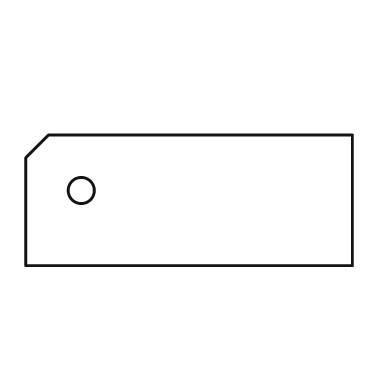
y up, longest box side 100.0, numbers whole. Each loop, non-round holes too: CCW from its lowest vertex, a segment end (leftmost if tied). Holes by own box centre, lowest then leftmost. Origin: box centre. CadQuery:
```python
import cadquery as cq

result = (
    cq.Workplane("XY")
    .moveTo(-50.0, -20.0)
    .lineTo(50.0, -20.0)
    .lineTo(50.0, 20.0)
    .lineTo(-43.0, 20.0)
    .lineTo(-50.0, 13.0)
    .close()
    .moveTo(-33.0, 3.0)
    .circle(4.0)
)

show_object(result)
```